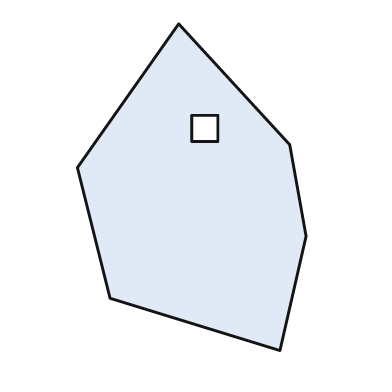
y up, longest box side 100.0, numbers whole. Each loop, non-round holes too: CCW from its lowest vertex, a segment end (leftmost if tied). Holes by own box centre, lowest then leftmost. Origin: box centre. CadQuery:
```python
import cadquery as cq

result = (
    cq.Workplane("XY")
    .moveTo(27.0, -50.0)
    .lineTo(35.0, -15.0)
    .lineTo(30.0, 13.0)
    .lineTo(-4.0, 50.0)
    .lineTo(-35.0, 6.0)
    .lineTo(-25.0, -34.0)
    .close()
    .moveTo(0.0, 14.0)
    .lineTo(8.0, 14.0)
    .lineTo(8.0, 22.0)
    .lineTo(0.0, 22.0)
    .close()
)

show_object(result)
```